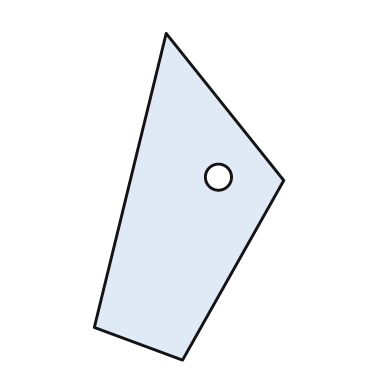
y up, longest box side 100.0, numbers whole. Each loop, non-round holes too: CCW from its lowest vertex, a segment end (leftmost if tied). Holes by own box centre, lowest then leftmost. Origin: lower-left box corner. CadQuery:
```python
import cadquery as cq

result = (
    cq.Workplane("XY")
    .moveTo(27.0, 0.0)
    .lineTo(58.0, 55.0)
    .lineTo(22.0, 100.0)
    .lineTo(0.0, 10.0)
    .close()
    .moveTo(38.0, 56.0)
    .circle(4.0)
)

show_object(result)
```